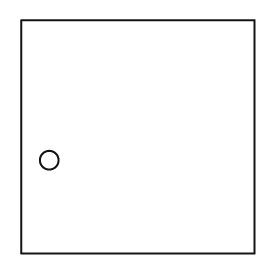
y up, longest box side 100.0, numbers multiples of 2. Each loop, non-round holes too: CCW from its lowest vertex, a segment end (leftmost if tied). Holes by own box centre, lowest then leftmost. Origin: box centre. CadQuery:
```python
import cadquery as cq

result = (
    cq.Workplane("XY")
    .moveTo(-50.0, -50.0)
    .lineTo(50.0, -50.0)
    .lineTo(50.0, 50.0)
    .lineTo(-50.0, 50.0)
    .close()
    .moveTo(-38.0, -10.0)
    .circle(4.0)
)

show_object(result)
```